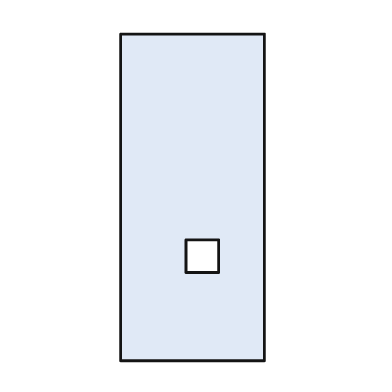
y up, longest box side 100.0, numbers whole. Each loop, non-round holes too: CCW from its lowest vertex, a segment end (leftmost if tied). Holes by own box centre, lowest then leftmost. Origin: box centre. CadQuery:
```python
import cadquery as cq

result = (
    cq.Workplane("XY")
    .moveTo(-22.0, -50.0)
    .lineTo(22.0, -50.0)
    .lineTo(22.0, 50.0)
    .lineTo(-22.0, 50.0)
    .close()
    .moveTo(-2.0, -23.0)
    .lineTo(8.0, -23.0)
    .lineTo(8.0, -13.0)
    .lineTo(-2.0, -13.0)
    .close()
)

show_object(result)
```